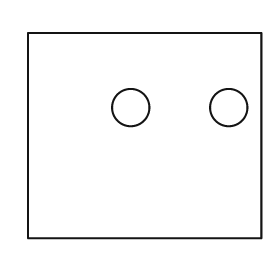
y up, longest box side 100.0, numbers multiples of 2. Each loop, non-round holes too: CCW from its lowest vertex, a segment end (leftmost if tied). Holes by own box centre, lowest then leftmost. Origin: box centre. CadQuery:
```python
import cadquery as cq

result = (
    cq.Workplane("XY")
    .moveTo(-50.0, -44.0)
    .lineTo(50.0, -44.0)
    .lineTo(50.0, 44.0)
    .lineTo(-50.0, 44.0)
    .close()
    .moveTo(-6.0, 12.0)
    .circle(8.0)
    .moveTo(36.0, 12.0)
    .circle(8.0)
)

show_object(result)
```